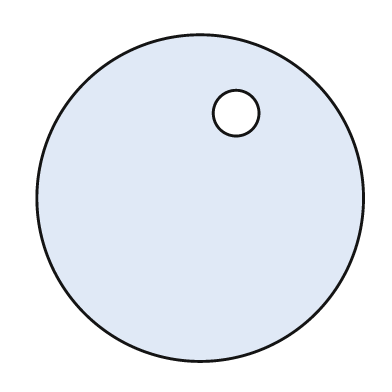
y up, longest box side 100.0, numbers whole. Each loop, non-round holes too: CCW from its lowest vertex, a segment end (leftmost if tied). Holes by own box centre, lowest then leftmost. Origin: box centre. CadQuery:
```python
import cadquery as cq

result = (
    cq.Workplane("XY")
    .moveTo(0.0, 0.0)
    .circle(50.0)
    .moveTo(11.0, 26.0)
    .circle(7.0)
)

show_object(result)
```